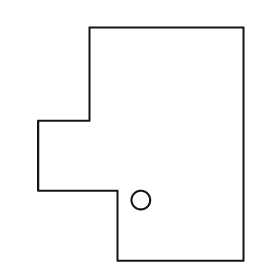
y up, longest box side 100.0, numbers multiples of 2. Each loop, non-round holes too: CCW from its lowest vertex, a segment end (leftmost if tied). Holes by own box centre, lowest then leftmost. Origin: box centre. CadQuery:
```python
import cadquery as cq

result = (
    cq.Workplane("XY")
    .moveTo(-10.0, -50.0)
    .lineTo(44.0, -50.0)
    .lineTo(44.0, 50.0)
    .lineTo(-22.0, 50.0)
    .lineTo(-22.0, 10.0)
    .lineTo(-44.0, 10.0)
    .lineTo(-44.0, -20.0)
    .lineTo(-10.0, -20.0)
    .close()
    .moveTo(0.0, -24.0)
    .circle(4.0)
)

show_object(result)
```